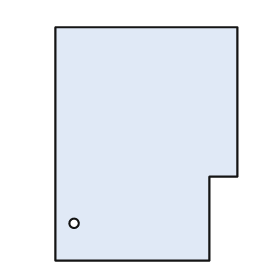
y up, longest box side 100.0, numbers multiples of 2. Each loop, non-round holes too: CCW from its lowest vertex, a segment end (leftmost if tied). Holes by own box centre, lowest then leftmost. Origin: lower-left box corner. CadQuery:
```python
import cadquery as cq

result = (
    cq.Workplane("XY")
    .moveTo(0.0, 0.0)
    .lineTo(66.0, 0.0)
    .lineTo(66.0, 36.0)
    .lineTo(78.0, 36.0)
    .lineTo(78.0, 100.0)
    .lineTo(0.0, 100.0)
    .close()
    .moveTo(8.0, 16.0)
    .circle(2.0)
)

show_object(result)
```